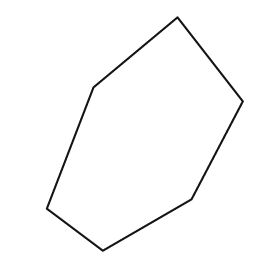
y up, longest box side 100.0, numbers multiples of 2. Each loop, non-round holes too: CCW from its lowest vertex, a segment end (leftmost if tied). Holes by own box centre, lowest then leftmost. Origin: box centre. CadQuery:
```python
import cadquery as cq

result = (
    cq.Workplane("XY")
    .moveTo(-18.0, -50.0)
    .lineTo(20.0, -28.0)
    .lineTo(42.0, 14.0)
    .lineTo(14.0, 50.0)
    .lineTo(-22.0, 20.0)
    .lineTo(-42.0, -32.0)
    .close()
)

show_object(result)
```